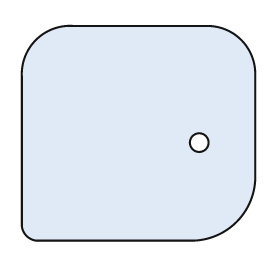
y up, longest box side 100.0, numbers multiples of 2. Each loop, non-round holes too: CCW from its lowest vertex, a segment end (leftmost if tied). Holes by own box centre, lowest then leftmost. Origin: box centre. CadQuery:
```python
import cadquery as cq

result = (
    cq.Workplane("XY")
    .moveTo(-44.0, -46.0)
    .lineTo(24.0, -46.0)
    .threePointArc((42.0, -38.0), (50.0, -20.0))
    .lineTo(50.0, 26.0)
    .threePointArc((44.0, 40.0), (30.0, 46.0))
    .lineTo(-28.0, 46.0)
    .threePointArc((-44.0, 40.0), (-50.0, 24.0))
    .lineTo(-50.0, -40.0)
    .threePointArc((-48.0, -44.0), (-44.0, -46.0))
    .close()
    .moveTo(26.0, -4.0)
    .circle(4.0)
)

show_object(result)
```